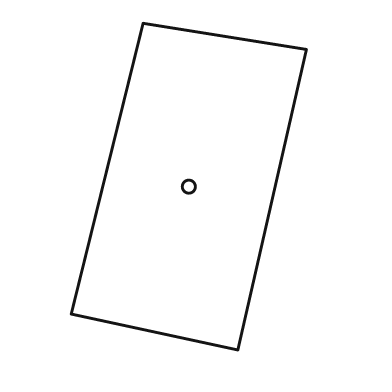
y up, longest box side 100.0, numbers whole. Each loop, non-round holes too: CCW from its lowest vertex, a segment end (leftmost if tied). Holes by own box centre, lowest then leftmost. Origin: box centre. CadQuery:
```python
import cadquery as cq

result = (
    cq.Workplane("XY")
    .moveTo(15.0, -50.0)
    .lineTo(36.0, 42.0)
    .lineTo(-14.0, 50.0)
    .lineTo(-36.0, -39.0)
    .close()
    .moveTo(0.0, 0.0)
    .circle(2.0)
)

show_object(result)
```